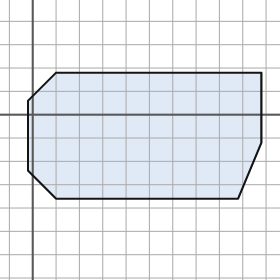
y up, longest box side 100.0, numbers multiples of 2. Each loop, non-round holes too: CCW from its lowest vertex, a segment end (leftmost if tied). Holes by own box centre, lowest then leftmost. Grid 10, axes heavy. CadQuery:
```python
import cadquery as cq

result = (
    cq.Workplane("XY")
    .moveTo(10.0, -36.0)
    .lineTo(88.0, -36.0)
    .lineTo(98.0, -12.0)
    .lineTo(98.0, 18.0)
    .lineTo(10.0, 18.0)
    .lineTo(-2.0, 6.0)
    .lineTo(-2.0, -24.0)
    .close()
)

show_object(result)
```